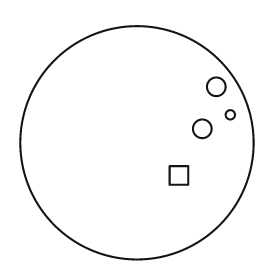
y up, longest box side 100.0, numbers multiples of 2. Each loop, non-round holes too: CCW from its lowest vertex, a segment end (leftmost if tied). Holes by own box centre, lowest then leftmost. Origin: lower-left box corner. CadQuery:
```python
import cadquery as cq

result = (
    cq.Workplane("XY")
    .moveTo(50.0, 50.0)
    .circle(50.0)
    .moveTo(64.0, 32.0)
    .lineTo(72.0, 32.0)
    .lineTo(72.0, 40.0)
    .lineTo(64.0, 40.0)
    .close()
    .moveTo(78.0, 56.0)
    .circle(4.0)
    .moveTo(90.0, 62.0)
    .circle(2.0)
    .moveTo(84.0, 74.0)
    .circle(4.0)
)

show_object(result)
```